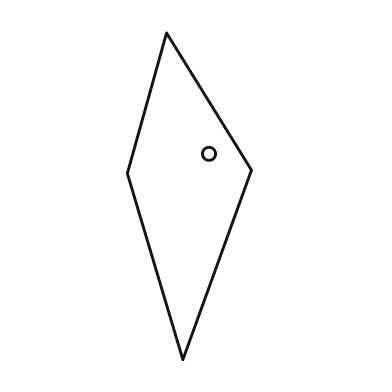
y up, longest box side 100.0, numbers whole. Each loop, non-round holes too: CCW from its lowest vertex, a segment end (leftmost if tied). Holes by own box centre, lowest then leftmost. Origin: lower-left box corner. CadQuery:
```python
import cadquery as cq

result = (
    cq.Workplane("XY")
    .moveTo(17.0, 0.0)
    .lineTo(38.0, 58.0)
    .lineTo(12.0, 100.0)
    .lineTo(0.0, 57.0)
    .close()
    .moveTo(25.0, 63.0)
    .circle(2.0)
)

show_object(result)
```